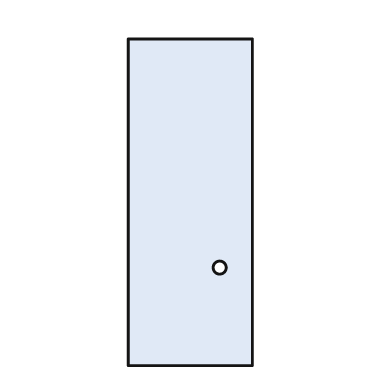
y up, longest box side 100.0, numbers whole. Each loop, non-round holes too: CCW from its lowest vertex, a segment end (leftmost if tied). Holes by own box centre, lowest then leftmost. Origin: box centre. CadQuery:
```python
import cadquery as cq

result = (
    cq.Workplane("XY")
    .moveTo(-19.0, -50.0)
    .lineTo(19.0, -50.0)
    .lineTo(19.0, 50.0)
    .lineTo(-19.0, 50.0)
    .close()
    .moveTo(9.0, -20.0)
    .circle(2.0)
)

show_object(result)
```